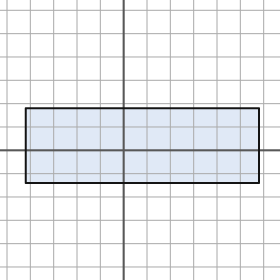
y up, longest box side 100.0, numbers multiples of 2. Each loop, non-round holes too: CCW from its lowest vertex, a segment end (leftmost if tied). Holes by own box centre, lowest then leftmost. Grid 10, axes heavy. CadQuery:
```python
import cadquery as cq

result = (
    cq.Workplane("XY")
    .moveTo(-42.0, -14.0)
    .lineTo(58.0, -14.0)
    .lineTo(58.0, 18.0)
    .lineTo(-42.0, 18.0)
    .close()
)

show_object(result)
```